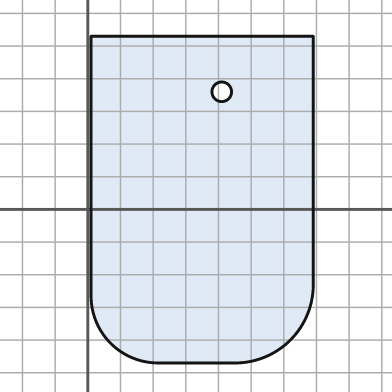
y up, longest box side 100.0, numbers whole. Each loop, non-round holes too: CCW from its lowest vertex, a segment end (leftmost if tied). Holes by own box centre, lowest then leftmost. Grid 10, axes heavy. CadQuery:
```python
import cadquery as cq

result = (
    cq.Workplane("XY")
    .moveTo(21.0, -47.0)
    .lineTo(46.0, -47.0)
    .threePointArc((62.0, -40.0), (69.0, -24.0))
    .lineTo(69.0, 53.0)
    .lineTo(1.0, 53.0)
    .lineTo(1.0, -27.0)
    .threePointArc((7.0, -41.0), (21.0, -47.0))
    .close()
    .moveTo(41.0, 36.0)
    .circle(3.0)
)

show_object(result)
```